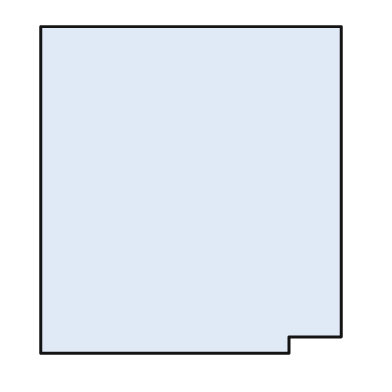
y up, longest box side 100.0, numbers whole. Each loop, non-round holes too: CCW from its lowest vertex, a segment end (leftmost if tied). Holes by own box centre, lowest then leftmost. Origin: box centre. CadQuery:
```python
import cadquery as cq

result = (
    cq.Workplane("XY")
    .moveTo(-46.0, -50.0)
    .lineTo(30.0, -50.0)
    .lineTo(30.0, -45.0)
    .lineTo(46.0, -45.0)
    .lineTo(46.0, 50.0)
    .lineTo(-46.0, 50.0)
    .close()
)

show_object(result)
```